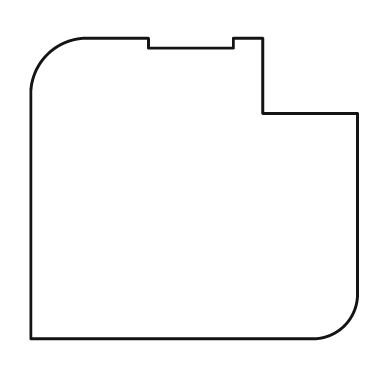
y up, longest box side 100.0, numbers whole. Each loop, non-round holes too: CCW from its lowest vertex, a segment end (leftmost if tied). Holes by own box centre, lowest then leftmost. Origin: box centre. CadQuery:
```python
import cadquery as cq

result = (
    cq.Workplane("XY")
    .moveTo(-50.0, -46.0)
    .lineTo(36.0, -46.0)
    .threePointArc((46.0, -42.0), (50.0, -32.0))
    .lineTo(50.0, 23.0)
    .lineTo(21.0, 23.0)
    .lineTo(21.0, 46.0)
    .lineTo(12.0, 46.0)
    .lineTo(12.0, 43.0)
    .lineTo(-14.0, 43.0)
    .lineTo(-14.0, 46.0)
    .lineTo(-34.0, 46.0)
    .threePointArc((-45.0, 41.0), (-50.0, 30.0))
    .close()
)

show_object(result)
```